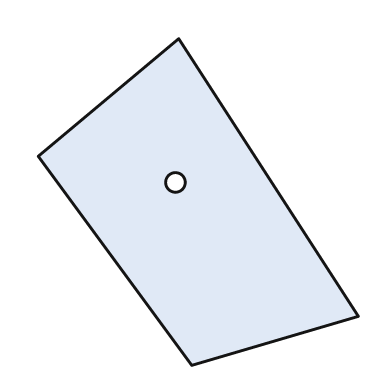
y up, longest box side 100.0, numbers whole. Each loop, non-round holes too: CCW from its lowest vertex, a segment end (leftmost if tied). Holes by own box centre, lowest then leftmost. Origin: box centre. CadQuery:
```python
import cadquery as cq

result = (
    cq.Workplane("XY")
    .moveTo(-2.0, -50.0)
    .lineTo(49.0, -35.0)
    .lineTo(-6.0, 50.0)
    .lineTo(-49.0, 14.0)
    .close()
    .moveTo(-7.0, 6.0)
    .circle(3.0)
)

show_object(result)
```